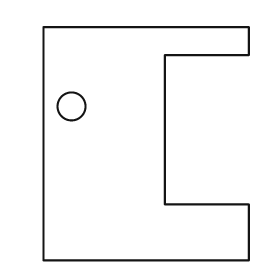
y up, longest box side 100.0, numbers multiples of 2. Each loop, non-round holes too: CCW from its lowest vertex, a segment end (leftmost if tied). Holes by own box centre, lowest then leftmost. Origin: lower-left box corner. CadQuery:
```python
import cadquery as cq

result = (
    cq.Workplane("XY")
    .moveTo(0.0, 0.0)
    .lineTo(88.0, 0.0)
    .lineTo(88.0, 24.0)
    .lineTo(52.0, 24.0)
    .lineTo(52.0, 88.0)
    .lineTo(88.0, 88.0)
    .lineTo(88.0, 100.0)
    .lineTo(0.0, 100.0)
    .close()
    .moveTo(12.0, 66.0)
    .circle(6.0)
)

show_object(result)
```